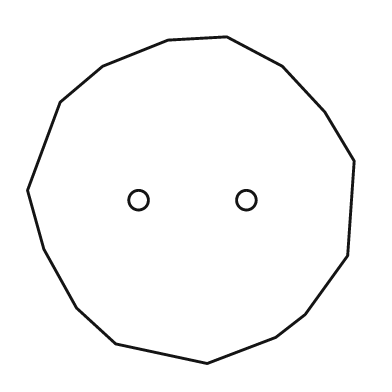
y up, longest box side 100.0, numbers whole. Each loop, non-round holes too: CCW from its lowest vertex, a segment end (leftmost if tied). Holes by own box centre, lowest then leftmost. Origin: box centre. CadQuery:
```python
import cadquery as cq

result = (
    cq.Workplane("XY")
    .moveTo(5.0, -50.0)
    .lineTo(26.0, -42.0)
    .lineTo(35.0, -35.0)
    .lineTo(48.0, -17.0)
    .lineTo(50.0, 12.0)
    .lineTo(41.0, 27.0)
    .lineTo(28.0, 41.0)
    .lineTo(11.0, 50.0)
    .lineTo(-7.0, 49.0)
    .lineTo(-27.0, 41.0)
    .lineTo(-40.0, 30.0)
    .lineTo(-50.0, 3.0)
    .lineTo(-45.0, -15.0)
    .lineTo(-35.0, -33.0)
    .lineTo(-23.0, -44.0)
    .close()
    .moveTo(-16.0, 0.0)
    .circle(3.0)
    .moveTo(17.0, 0.0)
    .circle(3.0)
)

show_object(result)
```